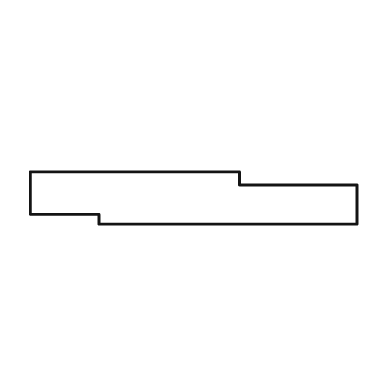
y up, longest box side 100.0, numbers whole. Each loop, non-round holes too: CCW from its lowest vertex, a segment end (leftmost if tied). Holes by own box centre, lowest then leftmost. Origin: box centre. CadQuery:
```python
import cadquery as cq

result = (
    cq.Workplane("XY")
    .moveTo(-29.0, -8.0)
    .lineTo(50.0, -8.0)
    .lineTo(50.0, 4.0)
    .lineTo(14.0, 4.0)
    .lineTo(14.0, 8.0)
    .lineTo(-50.0, 8.0)
    .lineTo(-50.0, -5.0)
    .lineTo(-29.0, -5.0)
    .close()
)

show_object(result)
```